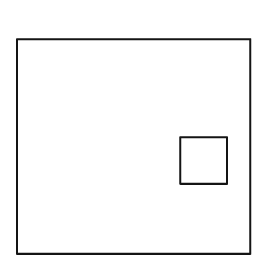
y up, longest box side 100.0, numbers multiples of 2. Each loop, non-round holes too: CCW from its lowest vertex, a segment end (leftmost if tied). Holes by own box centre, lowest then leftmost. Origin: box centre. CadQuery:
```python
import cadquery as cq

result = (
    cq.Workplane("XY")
    .moveTo(-50.0, -46.0)
    .lineTo(50.0, -46.0)
    .lineTo(50.0, 46.0)
    .lineTo(-50.0, 46.0)
    .close()
    .moveTo(20.0, -16.0)
    .lineTo(40.0, -16.0)
    .lineTo(40.0, 4.0)
    .lineTo(20.0, 4.0)
    .close()
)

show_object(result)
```